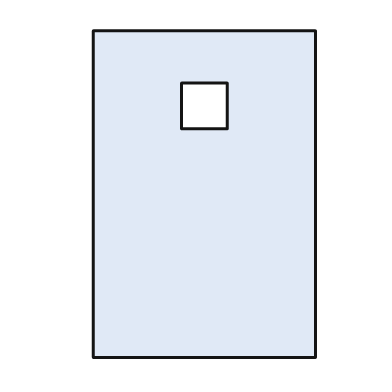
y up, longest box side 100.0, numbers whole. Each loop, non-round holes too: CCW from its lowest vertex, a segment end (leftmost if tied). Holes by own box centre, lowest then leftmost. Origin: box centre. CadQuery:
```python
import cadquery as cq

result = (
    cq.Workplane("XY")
    .moveTo(-34.0, -50.0)
    .lineTo(34.0, -50.0)
    .lineTo(34.0, 50.0)
    .lineTo(-34.0, 50.0)
    .close()
    .moveTo(-7.0, 20.0)
    .lineTo(7.0, 20.0)
    .lineTo(7.0, 34.0)
    .lineTo(-7.0, 34.0)
    .close()
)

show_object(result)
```